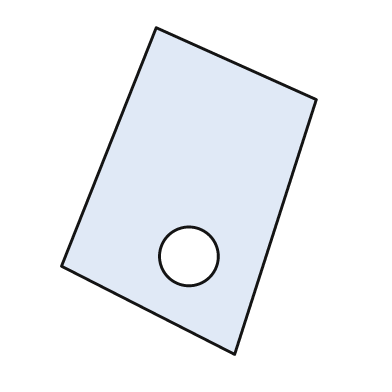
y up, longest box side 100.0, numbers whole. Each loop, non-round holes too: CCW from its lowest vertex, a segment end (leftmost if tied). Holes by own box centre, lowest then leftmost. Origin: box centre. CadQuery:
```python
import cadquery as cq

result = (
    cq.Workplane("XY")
    .moveTo(14.0, -50.0)
    .lineTo(39.0, 28.0)
    .lineTo(-10.0, 50.0)
    .lineTo(-39.0, -23.0)
    .close()
    .moveTo(0.0, -20.0)
    .circle(9.0)
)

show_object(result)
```